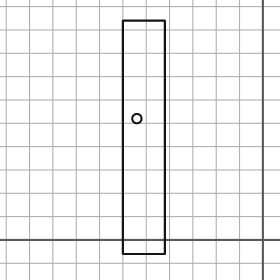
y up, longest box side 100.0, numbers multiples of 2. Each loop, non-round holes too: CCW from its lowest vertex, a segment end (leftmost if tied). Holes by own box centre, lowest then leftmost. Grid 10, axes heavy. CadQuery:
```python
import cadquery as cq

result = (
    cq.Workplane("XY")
    .moveTo(-60.0, -6.0)
    .lineTo(-42.0, -6.0)
    .lineTo(-42.0, 94.0)
    .lineTo(-60.0, 94.0)
    .close()
    .moveTo(-54.0, 52.0)
    .circle(2.0)
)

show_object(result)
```